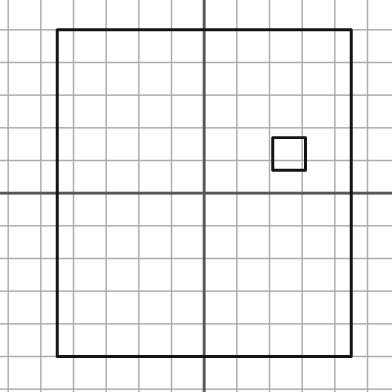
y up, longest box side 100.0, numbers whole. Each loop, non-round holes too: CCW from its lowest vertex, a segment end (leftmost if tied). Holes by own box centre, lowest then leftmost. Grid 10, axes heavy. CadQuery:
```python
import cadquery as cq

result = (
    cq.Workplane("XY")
    .moveTo(-45.0, -50.0)
    .lineTo(45.0, -50.0)
    .lineTo(45.0, 50.0)
    .lineTo(-45.0, 50.0)
    .close()
    .moveTo(21.0, 7.0)
    .lineTo(31.0, 7.0)
    .lineTo(31.0, 17.0)
    .lineTo(21.0, 17.0)
    .close()
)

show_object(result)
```